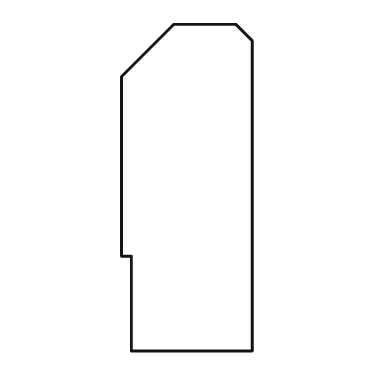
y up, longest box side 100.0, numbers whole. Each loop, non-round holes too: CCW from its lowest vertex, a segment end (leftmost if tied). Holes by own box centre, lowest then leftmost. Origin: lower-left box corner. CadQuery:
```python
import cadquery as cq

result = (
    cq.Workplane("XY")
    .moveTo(3.0, 0.0)
    .lineTo(40.0, 0.0)
    .lineTo(40.0, 95.0)
    .lineTo(35.0, 100.0)
    .lineTo(16.0, 100.0)
    .lineTo(0.0, 84.0)
    .lineTo(0.0, 29.0)
    .lineTo(3.0, 29.0)
    .close()
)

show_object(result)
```